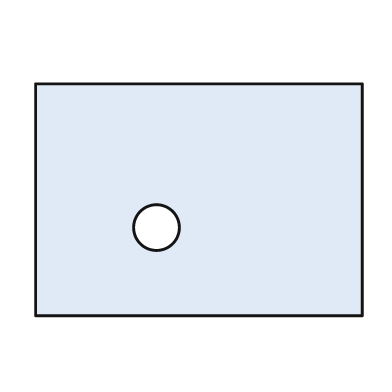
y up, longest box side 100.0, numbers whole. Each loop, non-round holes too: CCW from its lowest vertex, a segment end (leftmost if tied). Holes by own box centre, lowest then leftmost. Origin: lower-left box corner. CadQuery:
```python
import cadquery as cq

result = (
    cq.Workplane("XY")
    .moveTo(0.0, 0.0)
    .lineTo(100.0, 0.0)
    .lineTo(100.0, 71.0)
    .lineTo(0.0, 71.0)
    .close()
    .moveTo(37.0, 27.0)
    .circle(7.0)
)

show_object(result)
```